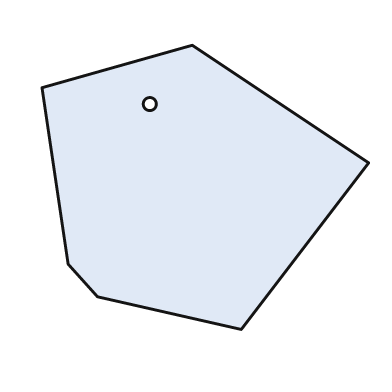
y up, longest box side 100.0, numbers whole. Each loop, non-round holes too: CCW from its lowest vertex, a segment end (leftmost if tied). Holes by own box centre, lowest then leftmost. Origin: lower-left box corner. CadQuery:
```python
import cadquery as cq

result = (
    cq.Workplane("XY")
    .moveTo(61.0, 0.0)
    .lineTo(100.0, 51.0)
    .lineTo(46.0, 87.0)
    .lineTo(0.0, 74.0)
    .lineTo(8.0, 20.0)
    .lineTo(17.0, 10.0)
    .close()
    .moveTo(33.0, 69.0)
    .circle(2.0)
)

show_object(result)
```